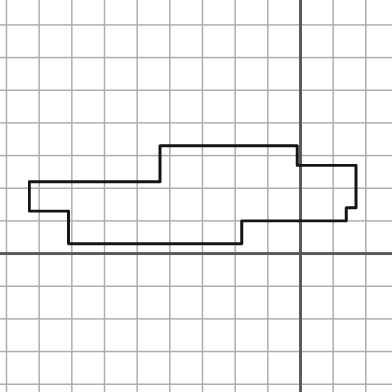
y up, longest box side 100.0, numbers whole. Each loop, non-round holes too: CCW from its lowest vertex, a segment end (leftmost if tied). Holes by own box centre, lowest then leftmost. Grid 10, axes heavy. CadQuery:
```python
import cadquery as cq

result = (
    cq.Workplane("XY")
    .moveTo(-71.0, 3.0)
    .lineTo(-18.0, 3.0)
    .lineTo(-18.0, 10.0)
    .lineTo(14.0, 10.0)
    .lineTo(14.0, 14.0)
    .lineTo(17.0, 14.0)
    .lineTo(17.0, 27.0)
    .lineTo(-1.0, 27.0)
    .lineTo(-1.0, 33.0)
    .lineTo(-43.0, 33.0)
    .lineTo(-43.0, 22.0)
    .lineTo(-83.0, 22.0)
    .lineTo(-83.0, 13.0)
    .lineTo(-71.0, 13.0)
    .close()
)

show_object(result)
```